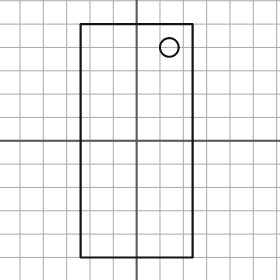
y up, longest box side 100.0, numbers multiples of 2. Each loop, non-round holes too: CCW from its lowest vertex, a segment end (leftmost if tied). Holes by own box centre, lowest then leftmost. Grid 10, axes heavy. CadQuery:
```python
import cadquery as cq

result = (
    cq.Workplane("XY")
    .moveTo(-24.0, -50.0)
    .lineTo(24.0, -50.0)
    .lineTo(24.0, 50.0)
    .lineTo(-24.0, 50.0)
    .close()
    .moveTo(14.0, 40.0)
    .circle(4.0)
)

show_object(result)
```